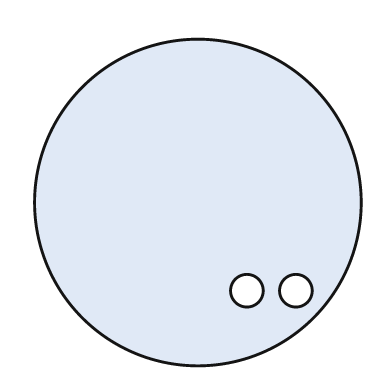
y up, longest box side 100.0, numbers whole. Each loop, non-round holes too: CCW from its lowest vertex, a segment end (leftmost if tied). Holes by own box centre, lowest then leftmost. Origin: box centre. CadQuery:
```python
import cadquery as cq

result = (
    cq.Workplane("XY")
    .moveTo(0.0, 0.0)
    .circle(50.0)
    .moveTo(15.0, -27.0)
    .circle(5.0)
    .moveTo(30.0, -27.0)
    .circle(5.0)
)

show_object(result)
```